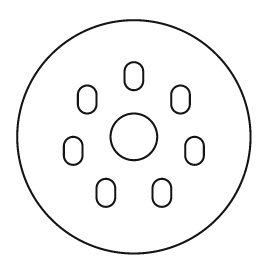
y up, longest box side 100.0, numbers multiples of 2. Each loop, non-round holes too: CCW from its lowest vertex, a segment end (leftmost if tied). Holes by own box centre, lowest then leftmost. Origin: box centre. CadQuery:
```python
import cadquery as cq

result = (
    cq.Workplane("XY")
    .moveTo(0.0, 0.0)
    .circle(50.0)
    .moveTo(-16.0, -26.0)
    .threePointArc((-12.0, -30.0), (-8.0, -26.0))
    .lineTo(-8.0, -22.0)
    .threePointArc((-12.0, -18.0), (-16.0, -22.0))
    .close()
    .moveTo(8.0, -26.0)
    .threePointArc((12.0, -30.0), (16.0, -26.0))
    .lineTo(16.0, -22.0)
    .threePointArc((12.0, -18.0), (8.0, -22.0))
    .close()
    .moveTo(-30.0, -8.0)
    .threePointArc((-26.0, -12.0), (-22.0, -8.0))
    .lineTo(-22.0, -4.0)
    .threePointArc((-26.0, 0.0), (-30.0, -4.0))
    .close()
    .moveTo(22.0, -8.0)
    .threePointArc((26.0, -12.0), (30.0, -8.0))
    .lineTo(30.0, -4.0)
    .threePointArc((26.0, 0.0), (22.0, -4.0))
    .close()
    .moveTo(0.0, 0.0)
    .circle(10.0)
    .moveTo(-24.0, 14.0)
    .threePointArc((-20.0, 10.0), (-16.0, 14.0))
    .lineTo(-16.0, 18.0)
    .threePointArc((-20.0, 22.0), (-24.0, 18.0))
    .close()
    .moveTo(16.0, 14.0)
    .threePointArc((20.0, 10.0), (24.0, 14.0))
    .lineTo(24.0, 18.0)
    .threePointArc((20.0, 22.0), (16.0, 18.0))
    .close()
    .moveTo(-4.0, 24.0)
    .threePointArc((0.0, 20.0), (4.0, 24.0))
    .lineTo(4.0, 28.0)
    .threePointArc((0.0, 32.0), (-4.0, 28.0))
    .close()
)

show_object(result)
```